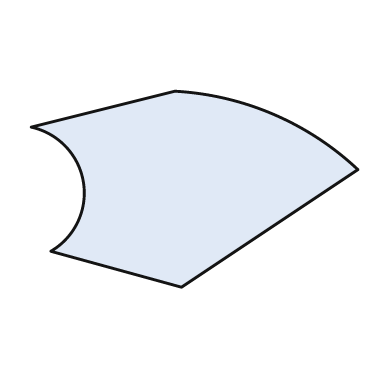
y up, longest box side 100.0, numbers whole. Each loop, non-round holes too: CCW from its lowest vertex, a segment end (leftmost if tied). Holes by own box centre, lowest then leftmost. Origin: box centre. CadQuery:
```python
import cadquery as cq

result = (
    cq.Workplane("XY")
    .moveTo(-4.0, -30.0)
    .lineTo(50.0, 6.0)
    .threePointArc((24.0, 23.0), (-6.0, 30.0))
    .lineTo(-50.0, 19.0)
    .threePointArc((-34.0, 2.0), (-44.0, -19.0))
    .close()
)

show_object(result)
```